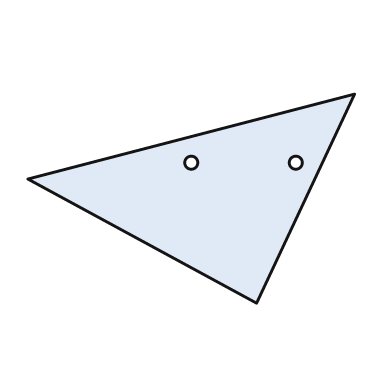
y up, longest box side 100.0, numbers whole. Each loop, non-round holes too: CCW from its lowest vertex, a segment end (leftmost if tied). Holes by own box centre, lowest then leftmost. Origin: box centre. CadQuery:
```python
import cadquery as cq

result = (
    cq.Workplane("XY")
    .moveTo(20.0, -32.0)
    .lineTo(50.0, 32.0)
    .lineTo(-50.0, 6.0)
    .close()
    .moveTo(0.0, 11.0)
    .circle(2.0)
    .moveTo(32.0, 11.0)
    .circle(2.0)
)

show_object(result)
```